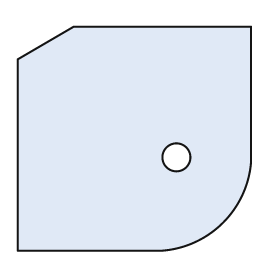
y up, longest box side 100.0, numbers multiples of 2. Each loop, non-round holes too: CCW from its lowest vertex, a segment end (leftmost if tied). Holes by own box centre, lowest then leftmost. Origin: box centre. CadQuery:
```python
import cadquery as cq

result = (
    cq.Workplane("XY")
    .moveTo(-50.0, -48.0)
    .lineTo(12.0, -48.0)
    .threePointArc((38.0, -36.0), (50.0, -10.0))
    .lineTo(50.0, 48.0)
    .lineTo(-26.0, 48.0)
    .lineTo(-50.0, 34.0)
    .close()
    .moveTo(18.0, -8.0)
    .circle(6.0)
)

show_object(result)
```